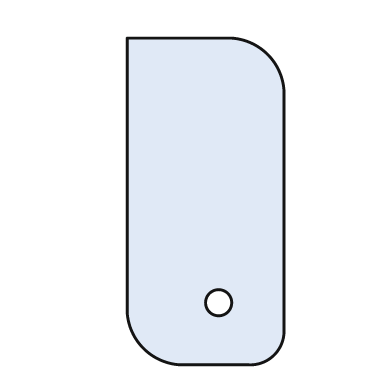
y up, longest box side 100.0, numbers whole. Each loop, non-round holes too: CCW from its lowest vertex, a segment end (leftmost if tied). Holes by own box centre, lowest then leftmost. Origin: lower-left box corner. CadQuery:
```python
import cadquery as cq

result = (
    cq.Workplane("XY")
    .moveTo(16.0, 0.0)
    .lineTo(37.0, 0.0)
    .threePointArc((45.0, 3.0), (48.0, 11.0))
    .lineTo(48.0, 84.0)
    .threePointArc((43.0, 95.0), (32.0, 100.0))
    .lineTo(0.0, 100.0)
    .lineTo(0.0, 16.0)
    .threePointArc((5.0, 5.0), (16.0, 0.0))
    .close()
    .moveTo(28.0, 19.0)
    .circle(4.0)
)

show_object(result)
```